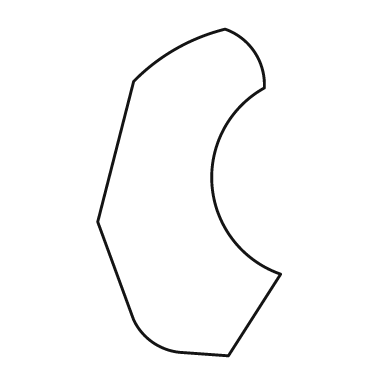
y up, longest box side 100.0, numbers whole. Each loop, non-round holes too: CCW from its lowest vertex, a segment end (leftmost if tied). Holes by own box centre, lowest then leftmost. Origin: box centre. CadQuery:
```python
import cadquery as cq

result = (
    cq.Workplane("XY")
    .moveTo(12.0, -50.0)
    .lineTo(28.0, -25.0)
    .threePointArc((7.0, 2.0), (23.0, 32.0))
    .threePointArc((20.0, 43.0), (11.0, 50.0))
    .threePointArc((-4.0, 44.0), (-17.0, 34.0))
    .lineTo(-28.0, -9.0)
    .lineTo(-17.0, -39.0)
    .threePointArc((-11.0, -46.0), (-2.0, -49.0))
    .close()
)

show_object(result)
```